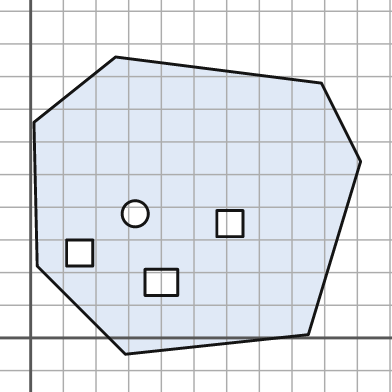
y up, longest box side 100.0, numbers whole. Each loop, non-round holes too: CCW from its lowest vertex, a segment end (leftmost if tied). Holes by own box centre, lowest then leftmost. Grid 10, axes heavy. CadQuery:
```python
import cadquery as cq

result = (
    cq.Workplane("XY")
    .moveTo(29.0, -5.0)
    .lineTo(85.0, 1.0)
    .lineTo(101.0, 54.0)
    .lineTo(89.0, 78.0)
    .lineTo(26.0, 86.0)
    .lineTo(1.0, 66.0)
    .lineTo(2.0, 22.0)
    .close()
    .moveTo(35.0, 13.0)
    .lineTo(45.0, 13.0)
    .lineTo(45.0, 21.0)
    .lineTo(35.0, 21.0)
    .close()
    .moveTo(11.0, 22.0)
    .lineTo(19.0, 22.0)
    .lineTo(19.0, 30.0)
    .lineTo(11.0, 30.0)
    .close()
    .moveTo(57.0, 31.0)
    .lineTo(65.0, 31.0)
    .lineTo(65.0, 39.0)
    .lineTo(57.0, 39.0)
    .close()
    .moveTo(32.0, 38.0)
    .circle(4.0)
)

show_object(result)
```